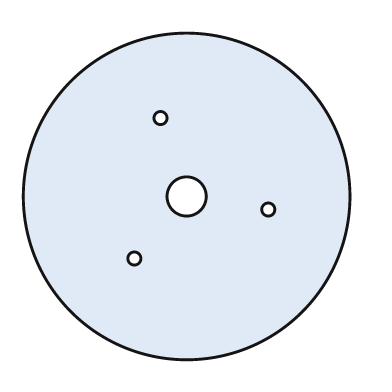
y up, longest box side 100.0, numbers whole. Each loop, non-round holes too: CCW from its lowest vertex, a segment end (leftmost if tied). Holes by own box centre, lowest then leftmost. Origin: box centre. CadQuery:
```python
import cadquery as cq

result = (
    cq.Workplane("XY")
    .moveTo(0.0, 0.0)
    .circle(50.0)
    .moveTo(-16.0, -19.0)
    .circle(2.0)
    .moveTo(25.0, -4.0)
    .circle(2.0)
    .moveTo(0.0, 0.0)
    .circle(6.0)
    .moveTo(-8.0, 24.0)
    .circle(2.0)
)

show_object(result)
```